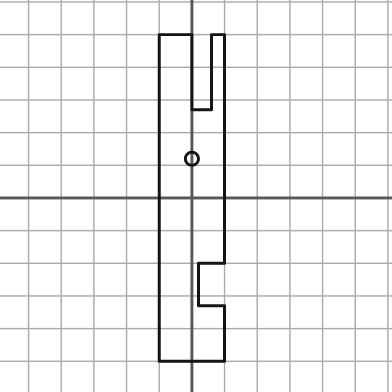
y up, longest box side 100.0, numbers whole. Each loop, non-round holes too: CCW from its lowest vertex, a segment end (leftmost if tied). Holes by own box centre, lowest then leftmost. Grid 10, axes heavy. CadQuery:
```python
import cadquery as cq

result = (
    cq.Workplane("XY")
    .moveTo(-10.0, -50.0)
    .lineTo(10.0, -50.0)
    .lineTo(10.0, -33.0)
    .lineTo(2.0, -33.0)
    .lineTo(2.0, -20.0)
    .lineTo(10.0, -20.0)
    .lineTo(10.0, 50.0)
    .lineTo(6.0, 50.0)
    .lineTo(6.0, 27.0)
    .lineTo(0.0, 27.0)
    .lineTo(0.0, 50.0)
    .lineTo(-10.0, 50.0)
    .close()
    .moveTo(0.0, 12.0)
    .circle(2.0)
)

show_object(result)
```